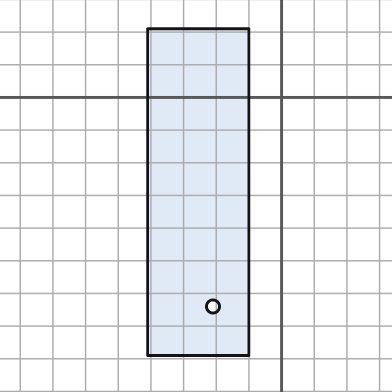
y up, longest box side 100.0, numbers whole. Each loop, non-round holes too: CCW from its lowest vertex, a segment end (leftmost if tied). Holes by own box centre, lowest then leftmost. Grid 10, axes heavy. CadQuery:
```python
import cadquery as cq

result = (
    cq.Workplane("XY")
    .moveTo(-41.0, -79.0)
    .lineTo(-10.0, -79.0)
    .lineTo(-10.0, 21.0)
    .lineTo(-41.0, 21.0)
    .close()
    .moveTo(-21.0, -64.0)
    .circle(2.0)
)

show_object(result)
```